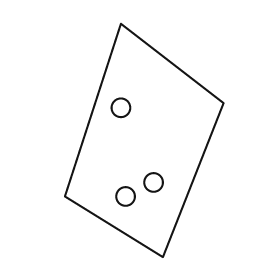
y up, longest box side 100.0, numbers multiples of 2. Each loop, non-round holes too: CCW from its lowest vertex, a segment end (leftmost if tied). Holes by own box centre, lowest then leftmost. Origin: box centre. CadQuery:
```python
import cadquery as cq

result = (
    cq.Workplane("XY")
    .moveTo(8.0, -50.0)
    .lineTo(34.0, 16.0)
    .lineTo(-10.0, 50.0)
    .lineTo(-34.0, -24.0)
    .close()
    .moveTo(-8.0, -24.0)
    .circle(4.0)
    .moveTo(4.0, -18.0)
    .circle(4.0)
    .moveTo(-10.0, 14.0)
    .circle(4.0)
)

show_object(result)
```